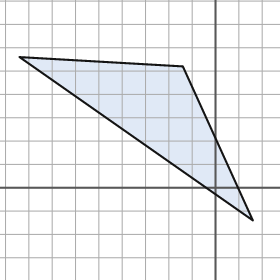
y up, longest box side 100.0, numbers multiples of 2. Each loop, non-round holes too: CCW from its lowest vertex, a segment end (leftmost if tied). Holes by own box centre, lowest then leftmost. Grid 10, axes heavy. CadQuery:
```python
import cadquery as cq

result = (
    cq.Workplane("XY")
    .moveTo(16.0, -14.0)
    .lineTo(-14.0, 52.0)
    .lineTo(-84.0, 56.0)
    .close()
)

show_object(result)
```